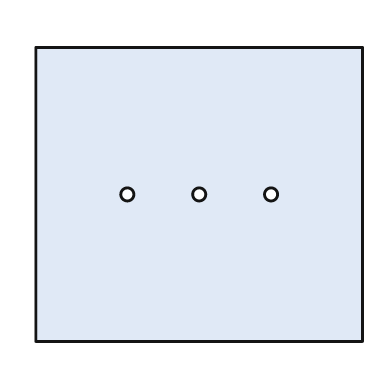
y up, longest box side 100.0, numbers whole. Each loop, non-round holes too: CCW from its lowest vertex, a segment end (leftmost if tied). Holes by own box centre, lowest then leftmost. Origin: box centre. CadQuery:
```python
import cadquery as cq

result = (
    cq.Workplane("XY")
    .moveTo(-50.0, -45.0)
    .lineTo(50.0, -45.0)
    .lineTo(50.0, 45.0)
    .lineTo(-50.0, 45.0)
    .close()
    .moveTo(-22.0, 0.0)
    .circle(2.0)
    .moveTo(0.0, 0.0)
    .circle(2.0)
    .moveTo(22.0, 0.0)
    .circle(2.0)
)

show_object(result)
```